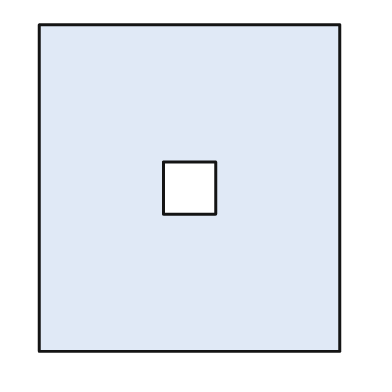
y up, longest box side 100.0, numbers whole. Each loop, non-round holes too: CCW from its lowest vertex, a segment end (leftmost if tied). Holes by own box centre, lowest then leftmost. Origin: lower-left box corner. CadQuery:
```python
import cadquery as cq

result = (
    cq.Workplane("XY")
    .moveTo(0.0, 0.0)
    .lineTo(92.0, 0.0)
    .lineTo(92.0, 100.0)
    .lineTo(0.0, 100.0)
    .close()
    .moveTo(38.0, 42.0)
    .lineTo(54.0, 42.0)
    .lineTo(54.0, 58.0)
    .lineTo(38.0, 58.0)
    .close()
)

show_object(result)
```